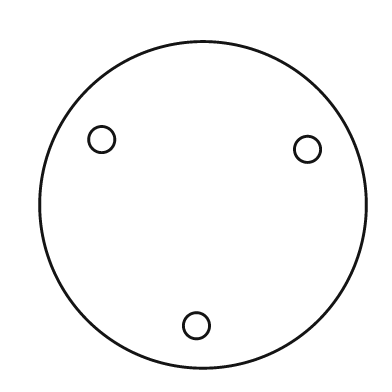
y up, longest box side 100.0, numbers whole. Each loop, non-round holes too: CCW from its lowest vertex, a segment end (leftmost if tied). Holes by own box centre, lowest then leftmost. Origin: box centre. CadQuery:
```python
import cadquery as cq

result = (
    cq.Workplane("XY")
    .moveTo(0.0, 0.0)
    .circle(50.0)
    .moveTo(-2.0, -37.0)
    .circle(4.0)
    .moveTo(32.0, 17.0)
    .circle(4.0)
    .moveTo(-31.0, 20.0)
    .circle(4.0)
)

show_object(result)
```